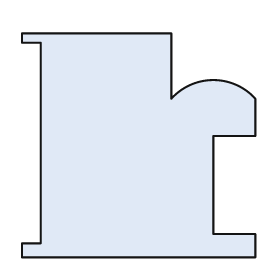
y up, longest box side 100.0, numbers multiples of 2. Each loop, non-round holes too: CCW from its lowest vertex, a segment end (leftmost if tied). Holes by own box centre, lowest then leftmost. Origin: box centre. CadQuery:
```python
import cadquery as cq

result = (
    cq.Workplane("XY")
    .moveTo(-50.0, -48.0)
    .lineTo(50.0, -48.0)
    .lineTo(50.0, -38.0)
    .lineTo(32.0, -38.0)
    .lineTo(32.0, 4.0)
    .lineTo(50.0, 4.0)
    .lineTo(50.0, 20.0)
    .threePointArc((32.0, 28.0), (14.0, 20.0))
    .lineTo(14.0, 48.0)
    .lineTo(-50.0, 48.0)
    .lineTo(-50.0, 44.0)
    .lineTo(-42.0, 44.0)
    .lineTo(-42.0, -42.0)
    .lineTo(-50.0, -42.0)
    .close()
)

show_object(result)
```